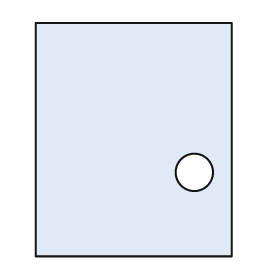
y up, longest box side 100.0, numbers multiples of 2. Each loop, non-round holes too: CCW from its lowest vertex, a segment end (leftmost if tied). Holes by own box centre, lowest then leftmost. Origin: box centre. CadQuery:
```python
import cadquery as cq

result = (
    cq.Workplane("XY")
    .moveTo(-42.0, -50.0)
    .lineTo(42.0, -50.0)
    .lineTo(42.0, 50.0)
    .lineTo(-42.0, 50.0)
    .close()
    .moveTo(26.0, -14.0)
    .circle(8.0)
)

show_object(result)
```